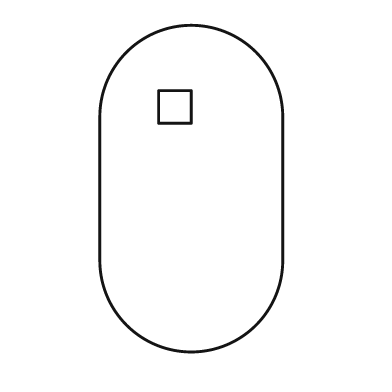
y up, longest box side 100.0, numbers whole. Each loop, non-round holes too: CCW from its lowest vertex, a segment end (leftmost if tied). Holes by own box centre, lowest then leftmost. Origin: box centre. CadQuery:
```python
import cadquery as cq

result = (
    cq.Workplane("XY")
    .moveTo(-28.0, -22.0)
    .threePointArc((0.0, -50.0), (28.0, -22.0))
    .lineTo(28.0, 22.0)
    .threePointArc((0.0, 50.0), (-28.0, 22.0))
    .close()
    .moveTo(-10.0, 20.0)
    .lineTo(0.0, 20.0)
    .lineTo(0.0, 30.0)
    .lineTo(-10.0, 30.0)
    .close()
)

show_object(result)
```